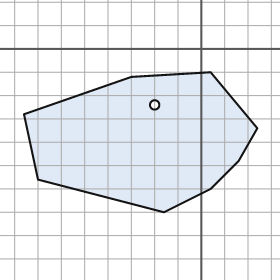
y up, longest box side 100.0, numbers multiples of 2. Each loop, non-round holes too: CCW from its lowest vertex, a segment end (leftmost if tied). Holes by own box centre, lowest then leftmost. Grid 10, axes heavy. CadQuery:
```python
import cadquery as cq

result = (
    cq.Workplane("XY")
    .moveTo(-16.0, -70.0)
    .lineTo(4.0, -60.0)
    .lineTo(16.0, -48.0)
    .lineTo(24.0, -34.0)
    .lineTo(4.0, -10.0)
    .lineTo(-30.0, -12.0)
    .lineTo(-76.0, -28.0)
    .lineTo(-70.0, -56.0)
    .close()
    .moveTo(-20.0, -24.0)
    .circle(2.0)
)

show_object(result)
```